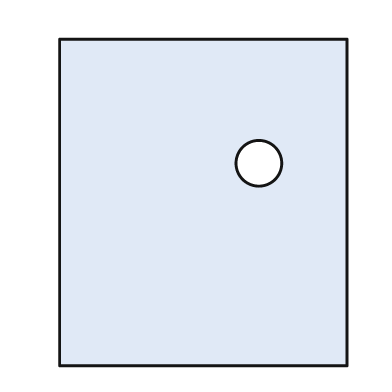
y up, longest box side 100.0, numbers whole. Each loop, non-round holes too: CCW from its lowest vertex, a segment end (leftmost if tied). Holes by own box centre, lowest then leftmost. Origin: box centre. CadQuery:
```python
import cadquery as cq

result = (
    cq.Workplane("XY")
    .moveTo(-44.0, -50.0)
    .lineTo(44.0, -50.0)
    .lineTo(44.0, 50.0)
    .lineTo(-44.0, 50.0)
    .close()
    .moveTo(17.0, 12.0)
    .circle(7.0)
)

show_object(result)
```